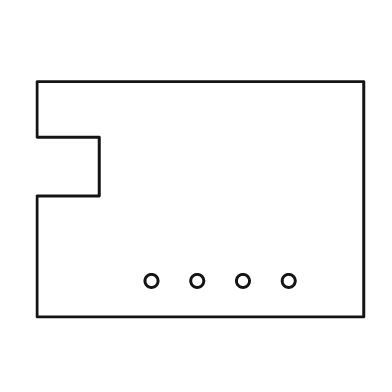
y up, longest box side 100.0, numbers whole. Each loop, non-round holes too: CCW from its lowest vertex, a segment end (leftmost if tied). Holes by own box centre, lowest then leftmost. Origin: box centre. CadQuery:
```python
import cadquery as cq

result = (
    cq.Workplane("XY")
    .moveTo(-50.0, -36.0)
    .lineTo(50.0, -36.0)
    .lineTo(50.0, 36.0)
    .lineTo(-50.0, 36.0)
    .lineTo(-50.0, 19.0)
    .lineTo(-31.0, 19.0)
    .lineTo(-31.0, 1.0)
    .lineTo(-50.0, 1.0)
    .close()
    .moveTo(-15.0, -25.0)
    .circle(2.0)
    .moveTo(-1.0, -25.0)
    .circle(2.0)
    .moveTo(13.0, -25.0)
    .circle(2.0)
    .moveTo(27.0, -25.0)
    .circle(2.0)
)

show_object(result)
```